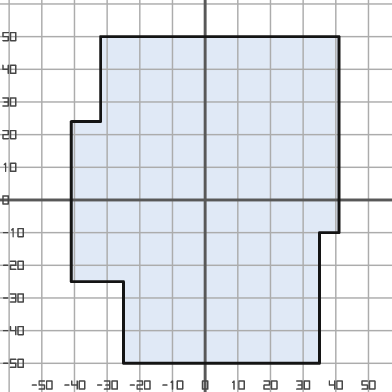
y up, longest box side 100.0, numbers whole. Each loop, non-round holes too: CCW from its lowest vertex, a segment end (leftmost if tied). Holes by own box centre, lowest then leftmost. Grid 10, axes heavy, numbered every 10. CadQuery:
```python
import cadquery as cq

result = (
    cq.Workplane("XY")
    .moveTo(-25.0, -50.0)
    .lineTo(35.0, -50.0)
    .lineTo(35.0, -10.0)
    .lineTo(41.0, -10.0)
    .lineTo(41.0, 50.0)
    .lineTo(-32.0, 50.0)
    .lineTo(-32.0, 24.0)
    .lineTo(-41.0, 24.0)
    .lineTo(-41.0, -25.0)
    .lineTo(-25.0, -25.0)
    .close()
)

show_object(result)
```